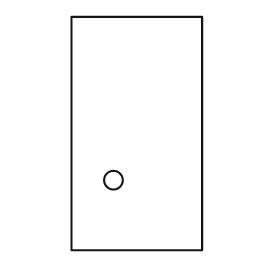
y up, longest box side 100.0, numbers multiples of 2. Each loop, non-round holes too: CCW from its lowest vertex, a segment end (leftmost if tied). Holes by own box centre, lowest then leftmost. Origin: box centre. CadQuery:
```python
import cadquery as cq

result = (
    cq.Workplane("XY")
    .moveTo(-28.0, -50.0)
    .lineTo(28.0, -50.0)
    .lineTo(28.0, 50.0)
    .lineTo(-28.0, 50.0)
    .close()
    .moveTo(-10.0, -20.0)
    .circle(4.0)
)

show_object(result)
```